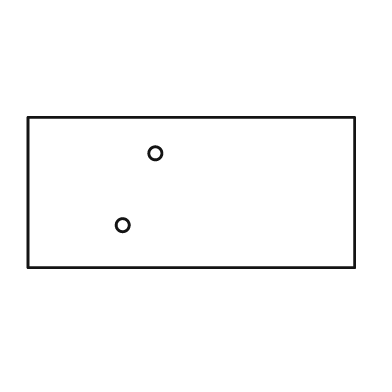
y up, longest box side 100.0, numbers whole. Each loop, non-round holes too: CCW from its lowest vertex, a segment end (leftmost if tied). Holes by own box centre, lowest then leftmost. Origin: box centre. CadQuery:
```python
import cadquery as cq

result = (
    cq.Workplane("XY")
    .moveTo(-50.0, -23.0)
    .lineTo(50.0, -23.0)
    .lineTo(50.0, 23.0)
    .lineTo(-50.0, 23.0)
    .close()
    .moveTo(-21.0, -10.0)
    .circle(2.0)
    .moveTo(-11.0, 12.0)
    .circle(2.0)
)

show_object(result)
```